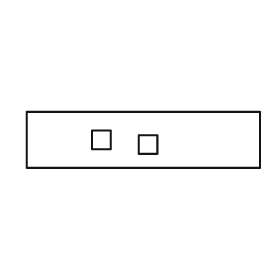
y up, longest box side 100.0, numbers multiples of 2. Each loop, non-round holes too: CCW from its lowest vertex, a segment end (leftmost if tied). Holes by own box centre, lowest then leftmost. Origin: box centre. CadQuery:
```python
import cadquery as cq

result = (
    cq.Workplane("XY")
    .moveTo(-50.0, -12.0)
    .lineTo(50.0, -12.0)
    .lineTo(50.0, 12.0)
    .lineTo(-50.0, 12.0)
    .close()
    .moveTo(-2.0, -6.0)
    .lineTo(6.0, -6.0)
    .lineTo(6.0, 2.0)
    .lineTo(-2.0, 2.0)
    .close()
    .moveTo(-22.0, -4.0)
    .lineTo(-14.0, -4.0)
    .lineTo(-14.0, 4.0)
    .lineTo(-22.0, 4.0)
    .close()
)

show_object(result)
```